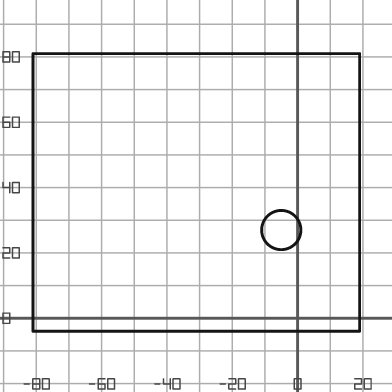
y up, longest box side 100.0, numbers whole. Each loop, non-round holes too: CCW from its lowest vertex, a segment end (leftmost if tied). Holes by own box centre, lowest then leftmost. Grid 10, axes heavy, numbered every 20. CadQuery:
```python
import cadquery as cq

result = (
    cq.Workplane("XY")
    .moveTo(-81.0, -4.0)
    .lineTo(19.0, -4.0)
    .lineTo(19.0, 81.0)
    .lineTo(-81.0, 81.0)
    .close()
    .moveTo(-5.0, 27.0)
    .circle(6.0)
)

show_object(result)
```